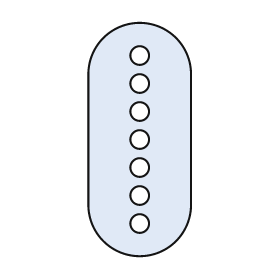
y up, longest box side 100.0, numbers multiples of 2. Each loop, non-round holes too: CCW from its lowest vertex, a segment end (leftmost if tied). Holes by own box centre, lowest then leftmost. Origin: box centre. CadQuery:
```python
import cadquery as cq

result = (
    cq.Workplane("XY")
    .moveTo(-22.0, -28.0)
    .threePointArc((0.0, -50.0), (22.0, -28.0))
    .lineTo(22.0, 28.0)
    .threePointArc((0.0, 50.0), (-22.0, 28.0))
    .close()
    .moveTo(0.0, -36.0)
    .circle(4.0)
    .moveTo(0.0, -24.0)
    .circle(4.0)
    .moveTo(0.0, -12.0)
    .circle(4.0)
    .moveTo(0.0, 0.0)
    .circle(4.0)
    .moveTo(0.0, 12.0)
    .circle(4.0)
    .moveTo(0.0, 24.0)
    .circle(4.0)
    .moveTo(0.0, 36.0)
    .circle(4.0)
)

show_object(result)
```